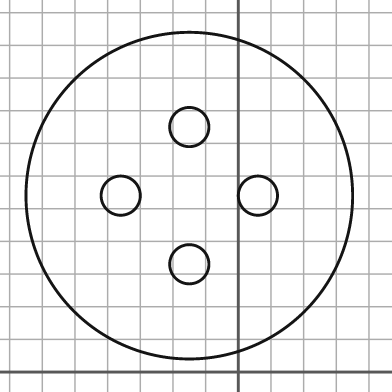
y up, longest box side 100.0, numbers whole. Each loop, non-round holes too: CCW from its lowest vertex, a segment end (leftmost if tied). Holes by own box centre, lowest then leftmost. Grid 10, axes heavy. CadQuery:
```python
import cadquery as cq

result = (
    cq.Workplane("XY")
    .moveTo(-15.0, 54.0)
    .circle(50.0)
    .moveTo(-15.0, 33.0)
    .circle(6.0)
    .moveTo(-36.0, 54.0)
    .circle(6.0)
    .moveTo(6.0, 54.0)
    .circle(6.0)
    .moveTo(-15.0, 75.0)
    .circle(6.0)
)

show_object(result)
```